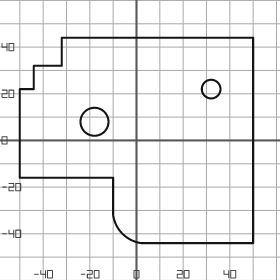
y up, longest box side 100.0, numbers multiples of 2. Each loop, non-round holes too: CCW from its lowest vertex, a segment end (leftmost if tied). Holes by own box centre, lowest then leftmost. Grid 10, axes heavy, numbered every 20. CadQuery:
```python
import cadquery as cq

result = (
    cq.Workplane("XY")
    .moveTo(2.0, -44.0)
    .lineTo(50.0, -44.0)
    .lineTo(50.0, 44.0)
    .lineTo(-32.0, 44.0)
    .lineTo(-32.0, 32.0)
    .lineTo(-44.0, 32.0)
    .lineTo(-44.0, 22.0)
    .lineTo(-50.0, 22.0)
    .lineTo(-50.0, -16.0)
    .lineTo(-10.0, -16.0)
    .lineTo(-10.0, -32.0)
    .threePointArc((-6.0, -40.0), (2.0, -44.0))
    .close()
    .moveTo(-18.0, 8.0)
    .circle(6.0)
    .moveTo(32.0, 22.0)
    .circle(4.0)
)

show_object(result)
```